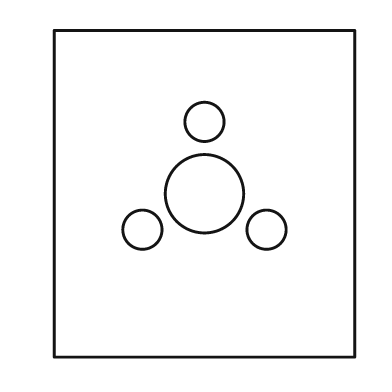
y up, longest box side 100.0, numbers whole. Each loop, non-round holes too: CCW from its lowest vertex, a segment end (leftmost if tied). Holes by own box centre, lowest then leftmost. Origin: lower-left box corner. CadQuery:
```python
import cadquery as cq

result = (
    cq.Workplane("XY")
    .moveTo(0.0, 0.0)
    .lineTo(92.0, 0.0)
    .lineTo(92.0, 100.0)
    .lineTo(0.0, 100.0)
    .close()
    .moveTo(27.0, 39.0)
    .circle(6.0)
    .moveTo(65.0, 39.0)
    .circle(6.0)
    .moveTo(46.0, 50.0)
    .circle(12.0)
    .moveTo(46.0, 72.0)
    .circle(6.0)
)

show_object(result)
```